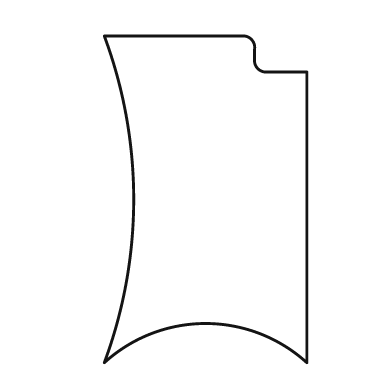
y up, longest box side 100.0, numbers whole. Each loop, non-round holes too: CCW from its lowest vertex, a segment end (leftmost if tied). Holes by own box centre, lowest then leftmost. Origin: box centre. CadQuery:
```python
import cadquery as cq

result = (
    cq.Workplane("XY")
    .moveTo(-31.0, -50.0)
    .threePointArc((0.0, -38.0), (31.0, -50.0))
    .lineTo(31.0, 39.0)
    .lineTo(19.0, 39.0)
    .threePointArc((16.0, 40.0), (15.0, 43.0))
    .lineTo(15.0, 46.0)
    .threePointArc((14.0, 49.0), (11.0, 50.0))
    .lineTo(-31.0, 50.0)
    .threePointArc((-22.0, 0.0), (-31.0, -50.0))
    .close()
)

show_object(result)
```